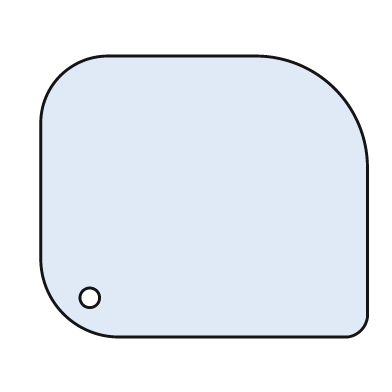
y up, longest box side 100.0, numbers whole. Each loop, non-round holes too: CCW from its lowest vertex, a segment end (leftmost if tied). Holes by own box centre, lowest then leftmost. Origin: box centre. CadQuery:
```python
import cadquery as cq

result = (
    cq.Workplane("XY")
    .moveTo(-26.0, -43.0)
    .lineTo(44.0, -43.0)
    .threePointArc((48.0, -41.0), (50.0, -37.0))
    .lineTo(50.0, 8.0)
    .threePointArc((40.0, 33.0), (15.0, 43.0))
    .lineTo(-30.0, 43.0)
    .threePointArc((-44.0, 37.0), (-50.0, 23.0))
    .lineTo(-50.0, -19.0)
    .threePointArc((-43.0, -36.0), (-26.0, -43.0))
    .close()
    .moveTo(-35.0, -31.0)
    .circle(3.0)
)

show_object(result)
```